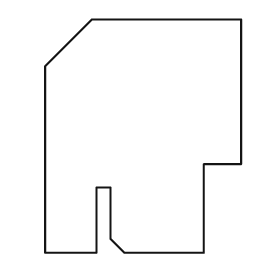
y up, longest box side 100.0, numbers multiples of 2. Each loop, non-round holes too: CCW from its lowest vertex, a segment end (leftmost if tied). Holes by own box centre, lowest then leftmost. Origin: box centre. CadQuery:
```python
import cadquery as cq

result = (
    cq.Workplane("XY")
    .moveTo(-42.0, -50.0)
    .lineTo(-20.0, -50.0)
    .lineTo(-20.0, -22.0)
    .lineTo(-14.0, -22.0)
    .lineTo(-14.0, -44.0)
    .lineTo(-8.0, -50.0)
    .lineTo(26.0, -50.0)
    .lineTo(26.0, -12.0)
    .lineTo(42.0, -12.0)
    .lineTo(42.0, 50.0)
    .lineTo(-22.0, 50.0)
    .lineTo(-42.0, 30.0)
    .close()
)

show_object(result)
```